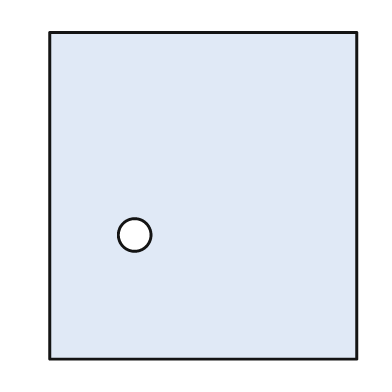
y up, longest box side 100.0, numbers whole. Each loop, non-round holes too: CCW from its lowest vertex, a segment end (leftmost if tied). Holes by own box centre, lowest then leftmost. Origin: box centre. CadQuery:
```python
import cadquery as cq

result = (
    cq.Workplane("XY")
    .moveTo(-47.0, -50.0)
    .lineTo(47.0, -50.0)
    .lineTo(47.0, 50.0)
    .lineTo(-47.0, 50.0)
    .close()
    .moveTo(-21.0, -12.0)
    .circle(5.0)
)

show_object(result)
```